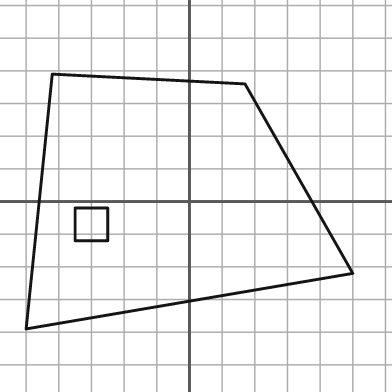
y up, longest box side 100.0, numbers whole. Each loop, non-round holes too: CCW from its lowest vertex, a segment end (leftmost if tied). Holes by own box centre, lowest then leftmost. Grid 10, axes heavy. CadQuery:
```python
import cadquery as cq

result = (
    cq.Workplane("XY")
    .moveTo(-50.0, -39.0)
    .lineTo(50.0, -22.0)
    .lineTo(17.0, 36.0)
    .lineTo(-42.0, 39.0)
    .close()
    .moveTo(-35.0, -12.0)
    .lineTo(-25.0, -12.0)
    .lineTo(-25.0, -2.0)
    .lineTo(-35.0, -2.0)
    .close()
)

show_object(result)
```